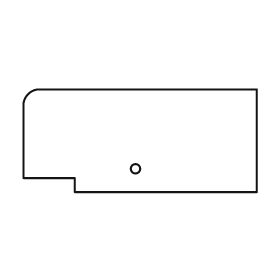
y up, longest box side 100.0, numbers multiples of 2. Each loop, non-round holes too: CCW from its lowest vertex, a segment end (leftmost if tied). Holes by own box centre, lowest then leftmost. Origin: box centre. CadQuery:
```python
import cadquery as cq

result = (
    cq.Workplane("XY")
    .moveTo(-28.0, -22.0)
    .lineTo(50.0, -22.0)
    .lineTo(50.0, 22.0)
    .lineTo(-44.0, 22.0)
    .threePointArc((-48.0, 20.0), (-50.0, 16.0))
    .lineTo(-50.0, -16.0)
    .lineTo(-28.0, -16.0)
    .close()
    .moveTo(-2.0, -12.0)
    .circle(2.0)
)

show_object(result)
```